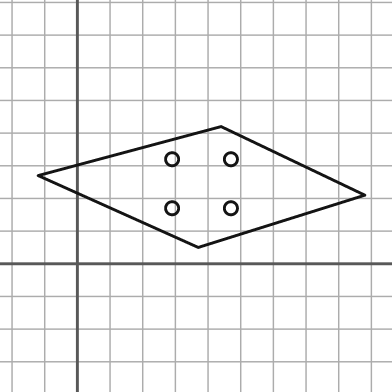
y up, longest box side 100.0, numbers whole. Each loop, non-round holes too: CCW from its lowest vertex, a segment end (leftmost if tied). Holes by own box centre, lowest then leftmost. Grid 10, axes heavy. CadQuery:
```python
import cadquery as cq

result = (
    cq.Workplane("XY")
    .moveTo(37.0, 5.0)
    .lineTo(88.0, 21.0)
    .lineTo(44.0, 42.0)
    .lineTo(-12.0, 27.0)
    .close()
    .moveTo(29.0, 17.0)
    .circle(2.0)
    .moveTo(47.0, 17.0)
    .circle(2.0)
    .moveTo(29.0, 32.0)
    .circle(2.0)
    .moveTo(47.0, 32.0)
    .circle(2.0)
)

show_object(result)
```